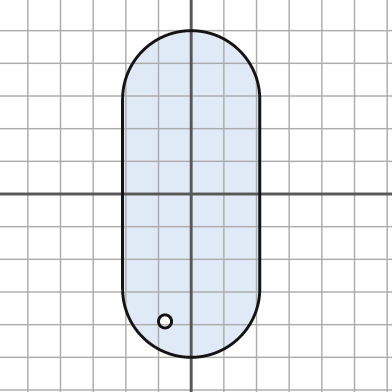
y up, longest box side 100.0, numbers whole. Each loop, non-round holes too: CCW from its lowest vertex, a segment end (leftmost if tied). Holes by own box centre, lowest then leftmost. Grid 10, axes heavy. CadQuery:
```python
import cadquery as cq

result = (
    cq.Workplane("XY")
    .moveTo(-21.0, -29.0)
    .threePointArc((0.0, -50.0), (21.0, -29.0))
    .lineTo(21.0, 29.0)
    .threePointArc((0.0, 50.0), (-21.0, 29.0))
    .close()
    .moveTo(-8.0, -39.0)
    .circle(2.0)
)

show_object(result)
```